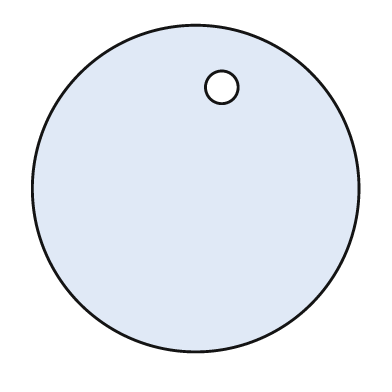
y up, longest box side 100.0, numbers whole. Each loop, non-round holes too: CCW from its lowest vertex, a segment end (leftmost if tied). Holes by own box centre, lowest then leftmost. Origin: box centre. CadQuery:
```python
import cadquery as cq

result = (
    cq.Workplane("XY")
    .moveTo(0.0, 0.0)
    .circle(50.0)
    .moveTo(8.0, 31.0)
    .circle(5.0)
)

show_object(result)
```